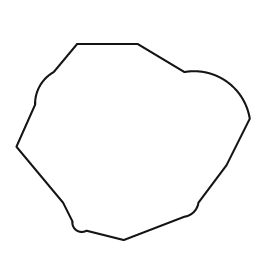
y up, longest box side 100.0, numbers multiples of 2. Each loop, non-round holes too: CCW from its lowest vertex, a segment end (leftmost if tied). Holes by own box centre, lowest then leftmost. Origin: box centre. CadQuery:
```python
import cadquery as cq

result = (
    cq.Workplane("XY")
    .moveTo(-4.0, -42.0)
    .lineTo(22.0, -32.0)
    .threePointArc((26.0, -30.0), (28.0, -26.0))
    .lineTo(40.0, -10.0)
    .lineTo(50.0, 10.0)
    .threePointArc((40.0, 26.0), (22.0, 30.0))
    .lineTo(2.0, 42.0)
    .lineTo(-24.0, 42.0)
    .lineTo(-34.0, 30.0)
    .threePointArc((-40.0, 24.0), (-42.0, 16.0))
    .lineTo(-50.0, -2.0)
    .lineTo(-30.0, -26.0)
    .lineTo(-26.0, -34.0)
    .threePointArc((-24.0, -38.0), (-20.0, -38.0))
    .close()
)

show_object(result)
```